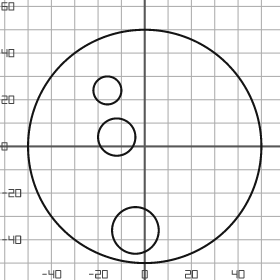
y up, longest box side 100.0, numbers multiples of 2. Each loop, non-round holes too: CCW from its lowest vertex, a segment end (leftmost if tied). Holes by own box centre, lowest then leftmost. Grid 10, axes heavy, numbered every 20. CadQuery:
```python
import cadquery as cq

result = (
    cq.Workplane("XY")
    .moveTo(0.0, 0.0)
    .circle(50.0)
    .moveTo(-4.0, -36.0)
    .circle(10.0)
    .moveTo(-12.0, 4.0)
    .circle(8.0)
    .moveTo(-16.0, 24.0)
    .circle(6.0)
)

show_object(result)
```